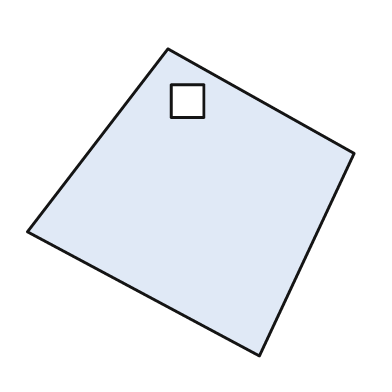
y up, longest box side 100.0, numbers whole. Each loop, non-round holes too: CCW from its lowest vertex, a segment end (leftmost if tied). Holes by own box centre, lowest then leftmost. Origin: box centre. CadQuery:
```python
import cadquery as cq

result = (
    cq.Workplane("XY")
    .moveTo(21.0, -47.0)
    .lineTo(50.0, 15.0)
    .lineTo(-7.0, 47.0)
    .lineTo(-50.0, -9.0)
    .close()
    .moveTo(-6.0, 26.0)
    .lineTo(4.0, 26.0)
    .lineTo(4.0, 36.0)
    .lineTo(-6.0, 36.0)
    .close()
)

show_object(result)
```